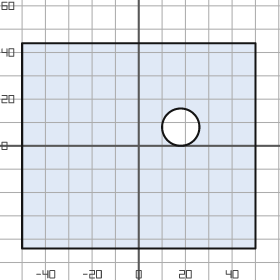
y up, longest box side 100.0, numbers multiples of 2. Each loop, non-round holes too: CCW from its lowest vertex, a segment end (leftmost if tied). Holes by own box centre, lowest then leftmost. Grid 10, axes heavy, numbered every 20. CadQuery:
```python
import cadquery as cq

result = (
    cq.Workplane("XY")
    .moveTo(-50.0, -44.0)
    .lineTo(50.0, -44.0)
    .lineTo(50.0, 44.0)
    .lineTo(-50.0, 44.0)
    .close()
    .moveTo(18.0, 8.0)
    .circle(8.0)
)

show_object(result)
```